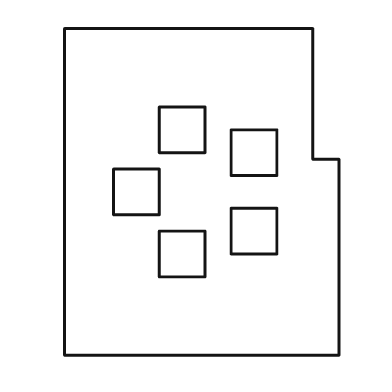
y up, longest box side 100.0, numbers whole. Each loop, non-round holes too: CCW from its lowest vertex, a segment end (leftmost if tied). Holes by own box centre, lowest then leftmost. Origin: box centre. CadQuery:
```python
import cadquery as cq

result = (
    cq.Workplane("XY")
    .moveTo(-42.0, -50.0)
    .lineTo(42.0, -50.0)
    .lineTo(42.0, 10.0)
    .lineTo(34.0, 10.0)
    .lineTo(34.0, 50.0)
    .lineTo(-42.0, 50.0)
    .close()
    .moveTo(-13.0, -26.0)
    .lineTo(1.0, -26.0)
    .lineTo(1.0, -12.0)
    .lineTo(-13.0, -12.0)
    .close()
    .moveTo(9.0, -19.0)
    .lineTo(23.0, -19.0)
    .lineTo(23.0, -5.0)
    .lineTo(9.0, -5.0)
    .close()
    .moveTo(-27.0, -7.0)
    .lineTo(-13.0, -7.0)
    .lineTo(-13.0, 7.0)
    .lineTo(-27.0, 7.0)
    .close()
    .moveTo(9.0, 5.0)
    .lineTo(23.0, 5.0)
    .lineTo(23.0, 19.0)
    .lineTo(9.0, 19.0)
    .close()
    .moveTo(-13.0, 12.0)
    .lineTo(1.0, 12.0)
    .lineTo(1.0, 26.0)
    .lineTo(-13.0, 26.0)
    .close()
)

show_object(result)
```